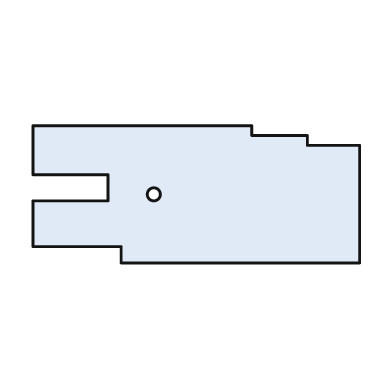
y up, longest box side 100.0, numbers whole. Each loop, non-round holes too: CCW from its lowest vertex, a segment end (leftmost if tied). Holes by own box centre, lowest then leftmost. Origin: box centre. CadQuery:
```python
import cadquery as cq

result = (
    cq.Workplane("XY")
    .moveTo(-23.0, -21.0)
    .lineTo(50.0, -21.0)
    .lineTo(50.0, 15.0)
    .lineTo(34.0, 15.0)
    .lineTo(34.0, 18.0)
    .lineTo(17.0, 18.0)
    .lineTo(17.0, 21.0)
    .lineTo(-50.0, 21.0)
    .lineTo(-50.0, 6.0)
    .lineTo(-27.0, 6.0)
    .lineTo(-27.0, -2.0)
    .lineTo(-50.0, -2.0)
    .lineTo(-50.0, -16.0)
    .lineTo(-23.0, -16.0)
    .close()
    .moveTo(-13.0, 0.0)
    .circle(2.0)
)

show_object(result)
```